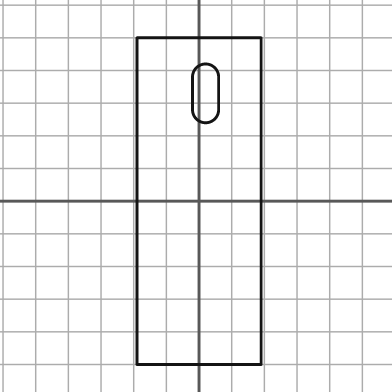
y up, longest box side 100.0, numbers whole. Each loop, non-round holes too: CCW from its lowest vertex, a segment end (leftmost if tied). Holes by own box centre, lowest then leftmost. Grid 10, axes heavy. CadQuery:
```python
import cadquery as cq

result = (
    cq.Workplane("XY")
    .moveTo(-19.0, -50.0)
    .lineTo(19.0, -50.0)
    .lineTo(19.0, 50.0)
    .lineTo(-19.0, 50.0)
    .close()
    .moveTo(-2.0, 28.0)
    .threePointArc((2.0, 24.0), (6.0, 28.0))
    .lineTo(6.0, 38.0)
    .threePointArc((2.0, 42.0), (-2.0, 38.0))
    .close()
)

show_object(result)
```